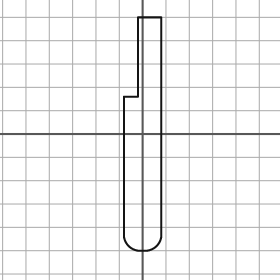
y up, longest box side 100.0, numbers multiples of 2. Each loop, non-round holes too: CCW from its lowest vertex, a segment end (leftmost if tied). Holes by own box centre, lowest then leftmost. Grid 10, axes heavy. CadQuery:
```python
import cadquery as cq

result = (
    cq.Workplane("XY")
    .moveTo(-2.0, -50.0)
    .lineTo(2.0, -50.0)
    .threePointArc((6.0, -48.0), (8.0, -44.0))
    .lineTo(8.0, 50.0)
    .lineTo(-2.0, 50.0)
    .lineTo(-2.0, 16.0)
    .lineTo(-8.0, 16.0)
    .lineTo(-8.0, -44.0)
    .threePointArc((-6.0, -48.0), (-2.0, -50.0))
    .close()
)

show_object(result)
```